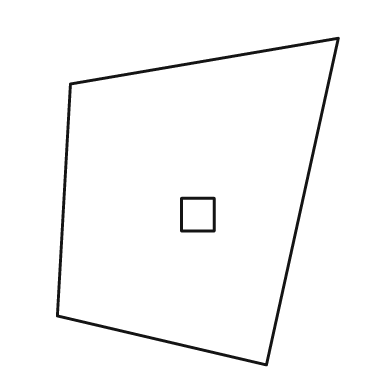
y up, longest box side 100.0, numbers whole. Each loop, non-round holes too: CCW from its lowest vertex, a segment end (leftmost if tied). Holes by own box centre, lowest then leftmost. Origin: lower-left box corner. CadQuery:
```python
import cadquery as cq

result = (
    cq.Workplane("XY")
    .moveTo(64.0, 0.0)
    .lineTo(86.0, 100.0)
    .lineTo(4.0, 86.0)
    .lineTo(0.0, 15.0)
    .close()
    .moveTo(38.0, 41.0)
    .lineTo(48.0, 41.0)
    .lineTo(48.0, 51.0)
    .lineTo(38.0, 51.0)
    .close()
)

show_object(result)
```